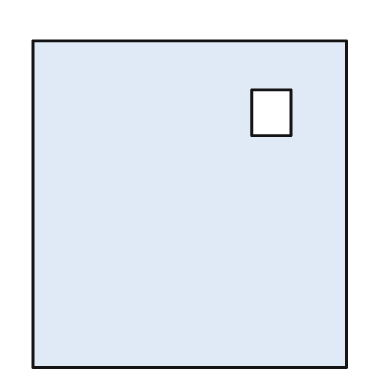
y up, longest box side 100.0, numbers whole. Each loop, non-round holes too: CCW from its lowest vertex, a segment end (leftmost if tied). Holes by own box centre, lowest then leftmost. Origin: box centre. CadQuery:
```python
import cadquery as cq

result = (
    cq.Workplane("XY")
    .moveTo(-48.0, -50.0)
    .lineTo(48.0, -50.0)
    .lineTo(48.0, 50.0)
    .lineTo(-48.0, 50.0)
    .close()
    .moveTo(19.0, 21.0)
    .lineTo(31.0, 21.0)
    .lineTo(31.0, 35.0)
    .lineTo(19.0, 35.0)
    .close()
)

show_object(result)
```